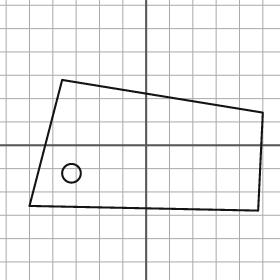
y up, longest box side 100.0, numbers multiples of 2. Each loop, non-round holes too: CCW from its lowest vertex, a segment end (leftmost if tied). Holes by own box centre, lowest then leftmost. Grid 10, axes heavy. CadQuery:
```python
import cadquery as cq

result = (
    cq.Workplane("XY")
    .moveTo(48.0, -28.0)
    .lineTo(50.0, 14.0)
    .lineTo(-36.0, 28.0)
    .lineTo(-50.0, -26.0)
    .close()
    .moveTo(-32.0, -12.0)
    .circle(4.0)
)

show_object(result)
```